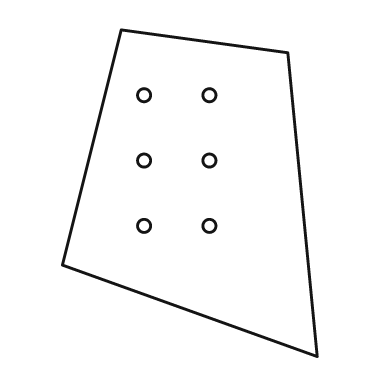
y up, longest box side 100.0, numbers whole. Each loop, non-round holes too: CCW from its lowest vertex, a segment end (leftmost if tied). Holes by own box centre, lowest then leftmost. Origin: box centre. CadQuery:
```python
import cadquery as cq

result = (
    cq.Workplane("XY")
    .moveTo(39.0, -50.0)
    .lineTo(30.0, 43.0)
    .lineTo(-21.0, 50.0)
    .lineTo(-39.0, -22.0)
    .close()
    .moveTo(-14.0, -10.0)
    .circle(2.0)
    .moveTo(6.0, -10.0)
    .circle(2.0)
    .moveTo(-14.0, 10.0)
    .circle(2.0)
    .moveTo(6.0, 10.0)
    .circle(2.0)
    .moveTo(-14.0, 30.0)
    .circle(2.0)
    .moveTo(6.0, 30.0)
    .circle(2.0)
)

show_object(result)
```